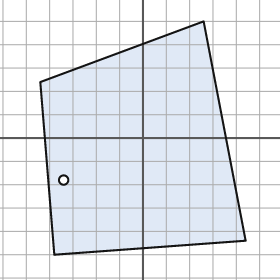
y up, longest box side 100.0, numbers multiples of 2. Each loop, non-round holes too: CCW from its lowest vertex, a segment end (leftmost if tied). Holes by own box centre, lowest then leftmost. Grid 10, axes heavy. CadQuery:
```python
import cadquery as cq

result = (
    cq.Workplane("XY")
    .moveTo(-38.0, -50.0)
    .lineTo(44.0, -44.0)
    .lineTo(26.0, 50.0)
    .lineTo(-44.0, 24.0)
    .close()
    .moveTo(-34.0, -18.0)
    .circle(2.0)
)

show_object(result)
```